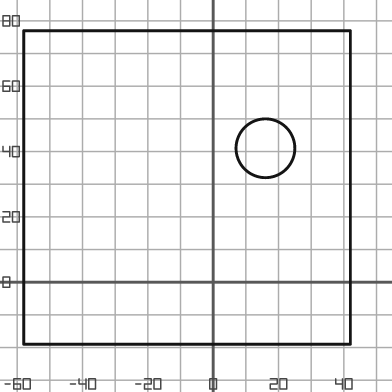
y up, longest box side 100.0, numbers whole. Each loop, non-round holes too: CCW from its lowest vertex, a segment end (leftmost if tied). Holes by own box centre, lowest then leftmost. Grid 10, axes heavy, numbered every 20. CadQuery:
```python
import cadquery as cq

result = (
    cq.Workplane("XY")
    .moveTo(-58.0, -19.0)
    .lineTo(42.0, -19.0)
    .lineTo(42.0, 77.0)
    .lineTo(-58.0, 77.0)
    .close()
    .moveTo(16.0, 41.0)
    .circle(9.0)
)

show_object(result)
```